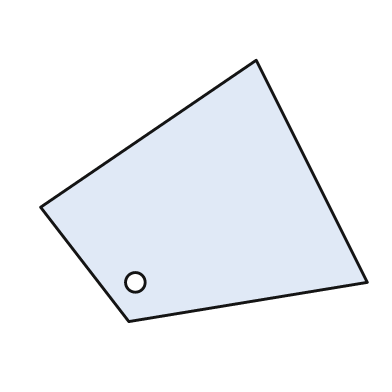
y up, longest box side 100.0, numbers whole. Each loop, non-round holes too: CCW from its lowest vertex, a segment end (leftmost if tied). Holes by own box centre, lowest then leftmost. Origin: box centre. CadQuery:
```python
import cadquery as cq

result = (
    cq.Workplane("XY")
    .moveTo(-23.0, -40.0)
    .lineTo(50.0, -28.0)
    .lineTo(16.0, 40.0)
    .lineTo(-50.0, -5.0)
    .close()
    .moveTo(-21.0, -28.0)
    .circle(3.0)
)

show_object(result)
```